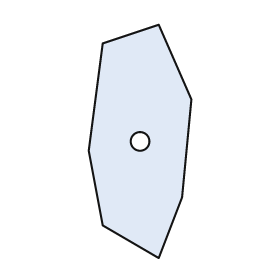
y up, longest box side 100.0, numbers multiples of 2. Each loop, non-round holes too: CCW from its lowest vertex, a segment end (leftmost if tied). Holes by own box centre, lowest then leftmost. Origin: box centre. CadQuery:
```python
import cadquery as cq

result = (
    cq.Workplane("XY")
    .moveTo(8.0, -50.0)
    .lineTo(18.0, -24.0)
    .lineTo(22.0, 18.0)
    .lineTo(8.0, 50.0)
    .lineTo(-16.0, 42.0)
    .lineTo(-22.0, -4.0)
    .lineTo(-16.0, -36.0)
    .close()
    .moveTo(0.0, 0.0)
    .circle(4.0)
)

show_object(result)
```